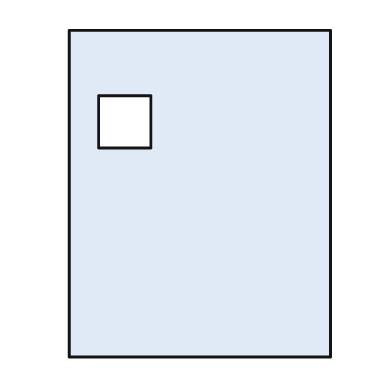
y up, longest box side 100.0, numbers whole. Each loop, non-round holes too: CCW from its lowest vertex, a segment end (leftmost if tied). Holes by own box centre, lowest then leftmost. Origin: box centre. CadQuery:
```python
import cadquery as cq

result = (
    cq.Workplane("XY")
    .moveTo(-40.0, -50.0)
    .lineTo(40.0, -50.0)
    .lineTo(40.0, 50.0)
    .lineTo(-40.0, 50.0)
    .close()
    .moveTo(-31.0, 14.0)
    .lineTo(-15.0, 14.0)
    .lineTo(-15.0, 30.0)
    .lineTo(-31.0, 30.0)
    .close()
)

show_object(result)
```